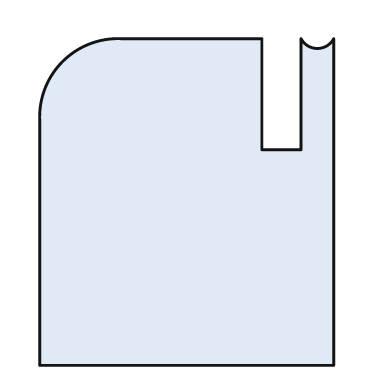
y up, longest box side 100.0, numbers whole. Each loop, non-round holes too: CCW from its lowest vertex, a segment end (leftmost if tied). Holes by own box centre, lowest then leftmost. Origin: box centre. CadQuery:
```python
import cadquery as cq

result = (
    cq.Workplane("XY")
    .moveTo(-45.0, -50.0)
    .lineTo(45.0, -50.0)
    .lineTo(45.0, 50.0)
    .threePointArc((40.0, 47.0), (35.0, 50.0))
    .lineTo(35.0, 16.0)
    .lineTo(23.0, 16.0)
    .lineTo(23.0, 50.0)
    .lineTo(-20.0, 50.0)
    .threePointArc((-38.0, 43.0), (-45.0, 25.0))
    .close()
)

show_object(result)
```